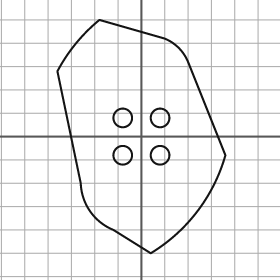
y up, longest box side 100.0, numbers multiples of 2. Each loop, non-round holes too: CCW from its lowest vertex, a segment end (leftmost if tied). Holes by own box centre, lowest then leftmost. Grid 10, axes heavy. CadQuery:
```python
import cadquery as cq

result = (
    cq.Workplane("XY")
    .moveTo(4.0, -50.0)
    .threePointArc((24.0, -32.0), (36.0, -8.0))
    .lineTo(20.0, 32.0)
    .threePointArc((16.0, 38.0), (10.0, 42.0))
    .lineTo(-18.0, 50.0)
    .threePointArc((-28.0, 40.0), (-36.0, 28.0))
    .lineTo(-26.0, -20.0)
    .threePointArc((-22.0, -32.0), (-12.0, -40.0))
    .close()
    .moveTo(-8.0, -8.0)
    .circle(4.0)
    .moveTo(8.0, -8.0)
    .circle(4.0)
    .moveTo(-8.0, 8.0)
    .circle(4.0)
    .moveTo(8.0, 8.0)
    .circle(4.0)
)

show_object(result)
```